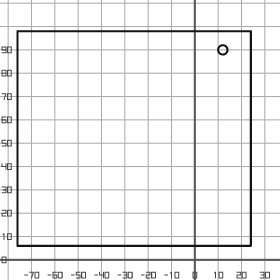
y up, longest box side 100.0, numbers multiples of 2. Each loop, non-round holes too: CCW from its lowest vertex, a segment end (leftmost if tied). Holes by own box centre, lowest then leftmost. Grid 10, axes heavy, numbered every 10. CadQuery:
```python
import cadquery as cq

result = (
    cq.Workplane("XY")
    .moveTo(-76.0, 6.0)
    .lineTo(24.0, 6.0)
    .lineTo(24.0, 98.0)
    .lineTo(-76.0, 98.0)
    .close()
    .moveTo(12.0, 90.0)
    .circle(2.0)
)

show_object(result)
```